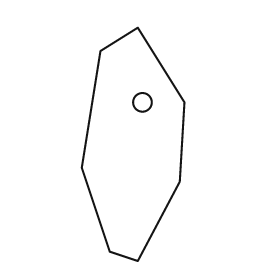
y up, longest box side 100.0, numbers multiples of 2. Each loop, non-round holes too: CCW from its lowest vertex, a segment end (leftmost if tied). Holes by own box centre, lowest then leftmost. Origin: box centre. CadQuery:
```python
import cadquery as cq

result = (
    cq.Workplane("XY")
    .moveTo(2.0, -50.0)
    .lineTo(20.0, -16.0)
    .lineTo(22.0, 18.0)
    .lineTo(2.0, 50.0)
    .lineTo(-14.0, 40.0)
    .lineTo(-22.0, -10.0)
    .lineTo(-10.0, -46.0)
    .close()
    .moveTo(4.0, 18.0)
    .circle(4.0)
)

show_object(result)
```